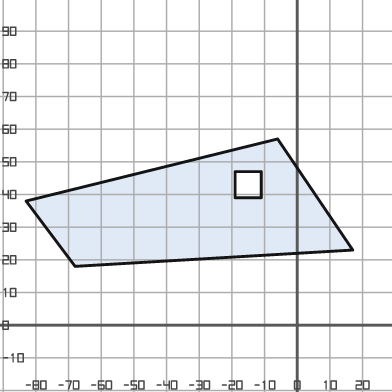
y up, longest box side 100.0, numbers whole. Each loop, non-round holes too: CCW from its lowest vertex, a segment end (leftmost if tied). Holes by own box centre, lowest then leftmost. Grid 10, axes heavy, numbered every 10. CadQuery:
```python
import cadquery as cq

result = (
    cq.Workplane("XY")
    .moveTo(-68.0, 18.0)
    .lineTo(17.0, 23.0)
    .lineTo(-6.0, 57.0)
    .lineTo(-83.0, 38.0)
    .close()
    .moveTo(-19.0, 39.0)
    .lineTo(-11.0, 39.0)
    .lineTo(-11.0, 47.0)
    .lineTo(-19.0, 47.0)
    .close()
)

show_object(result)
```